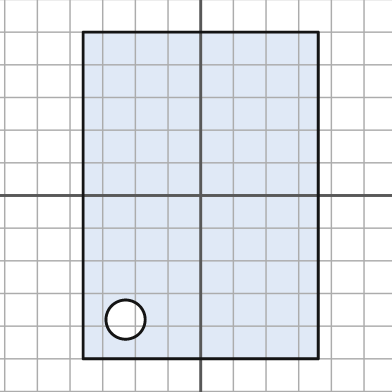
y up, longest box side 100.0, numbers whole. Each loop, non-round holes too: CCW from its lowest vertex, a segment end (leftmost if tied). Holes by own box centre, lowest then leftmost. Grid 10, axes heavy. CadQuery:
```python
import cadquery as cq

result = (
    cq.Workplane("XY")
    .moveTo(-36.0, -50.0)
    .lineTo(36.0, -50.0)
    .lineTo(36.0, 50.0)
    .lineTo(-36.0, 50.0)
    .close()
    .moveTo(-23.0, -38.0)
    .circle(6.0)
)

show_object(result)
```